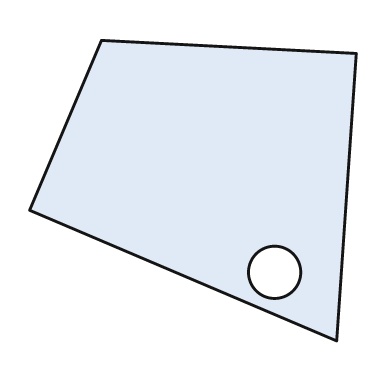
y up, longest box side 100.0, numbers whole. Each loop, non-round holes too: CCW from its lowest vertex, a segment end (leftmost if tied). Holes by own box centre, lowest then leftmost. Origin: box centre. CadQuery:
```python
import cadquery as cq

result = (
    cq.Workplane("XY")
    .moveTo(44.0, -46.0)
    .lineTo(50.0, 42.0)
    .lineTo(-28.0, 46.0)
    .lineTo(-50.0, -6.0)
    .close()
    .moveTo(25.0, -25.0)
    .circle(8.0)
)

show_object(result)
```